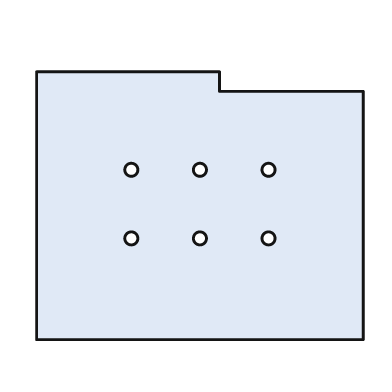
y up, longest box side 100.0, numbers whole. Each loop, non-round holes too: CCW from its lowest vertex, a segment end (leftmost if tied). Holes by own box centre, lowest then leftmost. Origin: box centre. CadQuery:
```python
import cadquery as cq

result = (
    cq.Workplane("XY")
    .moveTo(-50.0, -41.0)
    .lineTo(50.0, -41.0)
    .lineTo(50.0, 35.0)
    .lineTo(6.0, 35.0)
    .lineTo(6.0, 41.0)
    .lineTo(-50.0, 41.0)
    .close()
    .moveTo(-21.0, -10.0)
    .circle(2.0)
    .moveTo(0.0, -10.0)
    .circle(2.0)
    .moveTo(21.0, -10.0)
    .circle(2.0)
    .moveTo(-21.0, 11.0)
    .circle(2.0)
    .moveTo(0.0, 11.0)
    .circle(2.0)
    .moveTo(21.0, 11.0)
    .circle(2.0)
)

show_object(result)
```